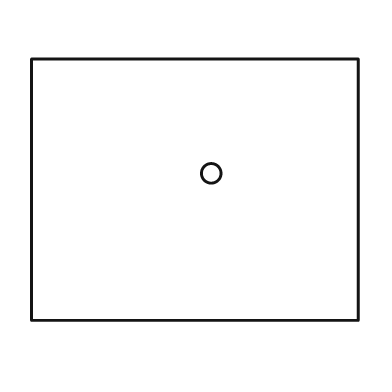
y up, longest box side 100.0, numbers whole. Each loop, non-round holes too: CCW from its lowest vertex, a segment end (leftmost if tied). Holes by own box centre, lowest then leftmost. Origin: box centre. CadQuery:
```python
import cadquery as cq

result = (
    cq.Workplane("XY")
    .moveTo(-50.0, -40.0)
    .lineTo(50.0, -40.0)
    .lineTo(50.0, 40.0)
    .lineTo(-50.0, 40.0)
    .close()
    .moveTo(5.0, 5.0)
    .circle(3.0)
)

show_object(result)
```